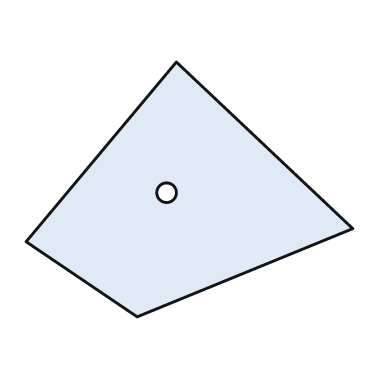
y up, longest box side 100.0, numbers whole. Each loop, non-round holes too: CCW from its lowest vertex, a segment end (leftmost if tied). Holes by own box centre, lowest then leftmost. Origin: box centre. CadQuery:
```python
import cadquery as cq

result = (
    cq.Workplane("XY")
    .moveTo(-16.0, -39.0)
    .lineTo(50.0, -12.0)
    .lineTo(-4.0, 39.0)
    .lineTo(-50.0, -16.0)
    .close()
    .moveTo(-7.0, -1.0)
    .circle(3.0)
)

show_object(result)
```